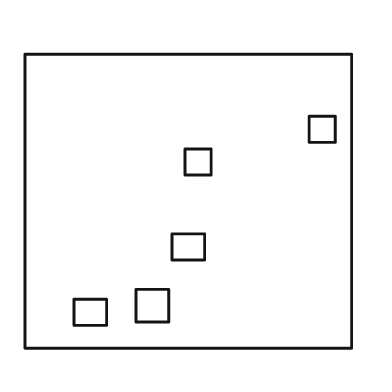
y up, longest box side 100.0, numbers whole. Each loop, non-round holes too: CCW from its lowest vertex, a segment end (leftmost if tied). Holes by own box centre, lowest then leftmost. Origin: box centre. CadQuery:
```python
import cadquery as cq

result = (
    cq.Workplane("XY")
    .moveTo(-50.0, -45.0)
    .lineTo(50.0, -45.0)
    .lineTo(50.0, 45.0)
    .lineTo(-50.0, 45.0)
    .close()
    .moveTo(-35.0, -38.0)
    .lineTo(-25.0, -38.0)
    .lineTo(-25.0, -30.0)
    .lineTo(-35.0, -30.0)
    .close()
    .moveTo(-16.0, -37.0)
    .lineTo(-6.0, -37.0)
    .lineTo(-6.0, -27.0)
    .lineTo(-16.0, -27.0)
    .close()
    .moveTo(-5.0, -18.0)
    .lineTo(5.0, -18.0)
    .lineTo(5.0, -10.0)
    .lineTo(-5.0, -10.0)
    .close()
    .moveTo(-1.0, 8.0)
    .lineTo(7.0, 8.0)
    .lineTo(7.0, 16.0)
    .lineTo(-1.0, 16.0)
    .close()
    .moveTo(37.0, 18.0)
    .lineTo(45.0, 18.0)
    .lineTo(45.0, 26.0)
    .lineTo(37.0, 26.0)
    .close()
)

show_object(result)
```